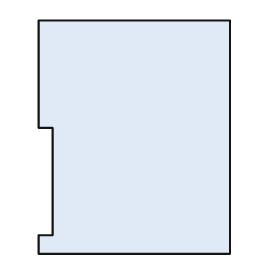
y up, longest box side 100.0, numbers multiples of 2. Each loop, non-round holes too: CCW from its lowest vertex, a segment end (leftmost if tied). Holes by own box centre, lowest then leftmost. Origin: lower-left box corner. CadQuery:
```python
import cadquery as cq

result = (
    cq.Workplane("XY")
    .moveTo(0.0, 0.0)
    .lineTo(82.0, 0.0)
    .lineTo(82.0, 100.0)
    .lineTo(0.0, 100.0)
    .lineTo(0.0, 54.0)
    .lineTo(6.0, 54.0)
    .lineTo(6.0, 8.0)
    .lineTo(0.0, 8.0)
    .close()
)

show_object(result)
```